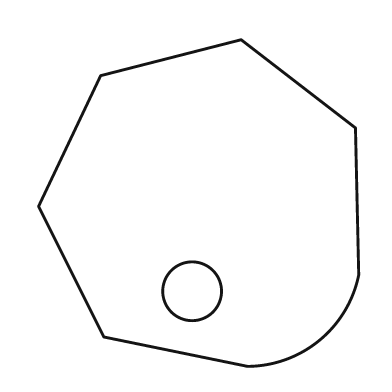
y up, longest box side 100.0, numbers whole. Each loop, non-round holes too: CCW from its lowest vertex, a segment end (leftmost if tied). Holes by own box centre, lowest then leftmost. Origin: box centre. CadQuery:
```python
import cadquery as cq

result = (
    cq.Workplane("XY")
    .moveTo(15.0, -50.0)
    .threePointArc((37.0, -42.0), (49.0, -22.0))
    .lineTo(48.0, 23.0)
    .lineTo(13.0, 50.0)
    .lineTo(-30.0, 39.0)
    .lineTo(-49.0, -1.0)
    .lineTo(-29.0, -41.0)
    .close()
    .moveTo(-2.0, -27.0)
    .circle(9.0)
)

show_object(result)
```